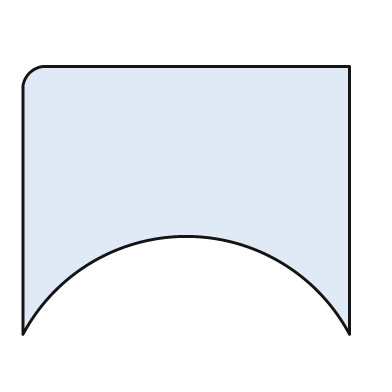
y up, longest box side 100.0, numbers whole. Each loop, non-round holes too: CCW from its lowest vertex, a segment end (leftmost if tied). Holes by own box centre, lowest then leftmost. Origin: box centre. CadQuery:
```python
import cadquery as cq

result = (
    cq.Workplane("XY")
    .moveTo(-50.0, -41.0)
    .threePointArc((0.0, -11.0), (50.0, -41.0))
    .lineTo(50.0, 41.0)
    .lineTo(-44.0, 41.0)
    .threePointArc((-48.0, 39.0), (-50.0, 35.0))
    .close()
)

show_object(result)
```